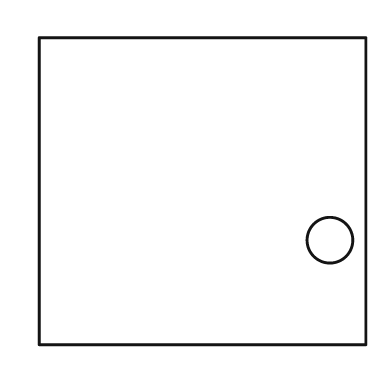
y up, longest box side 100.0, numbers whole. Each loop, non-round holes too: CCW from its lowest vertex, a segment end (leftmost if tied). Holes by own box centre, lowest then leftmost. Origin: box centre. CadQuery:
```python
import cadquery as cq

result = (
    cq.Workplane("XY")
    .moveTo(-50.0, -47.0)
    .lineTo(50.0, -47.0)
    .lineTo(50.0, 47.0)
    .lineTo(-50.0, 47.0)
    .close()
    .moveTo(39.0, -15.0)
    .circle(7.0)
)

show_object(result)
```